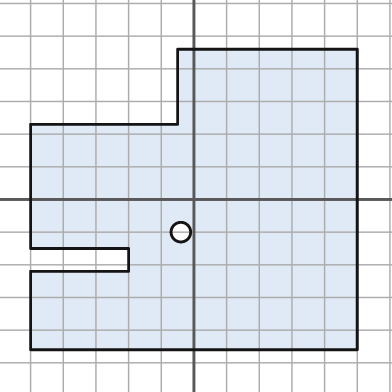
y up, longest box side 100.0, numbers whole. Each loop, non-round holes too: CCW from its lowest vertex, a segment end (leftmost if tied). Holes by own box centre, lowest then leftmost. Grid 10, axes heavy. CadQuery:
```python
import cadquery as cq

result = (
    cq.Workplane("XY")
    .moveTo(-50.0, -46.0)
    .lineTo(50.0, -46.0)
    .lineTo(50.0, 46.0)
    .lineTo(-5.0, 46.0)
    .lineTo(-5.0, 23.0)
    .lineTo(-50.0, 23.0)
    .lineTo(-50.0, -15.0)
    .lineTo(-20.0, -15.0)
    .lineTo(-20.0, -22.0)
    .lineTo(-50.0, -22.0)
    .close()
    .moveTo(-4.0, -10.0)
    .circle(3.0)
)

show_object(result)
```